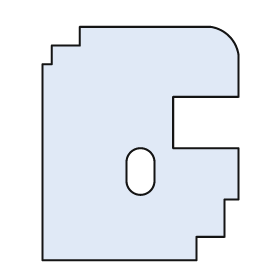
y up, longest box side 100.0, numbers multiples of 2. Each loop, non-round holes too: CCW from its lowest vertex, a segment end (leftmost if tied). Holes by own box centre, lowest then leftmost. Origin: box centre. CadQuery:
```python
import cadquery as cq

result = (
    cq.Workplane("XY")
    .moveTo(-42.0, -50.0)
    .lineTo(24.0, -50.0)
    .lineTo(24.0, -40.0)
    .lineTo(36.0, -40.0)
    .lineTo(36.0, -24.0)
    .lineTo(42.0, -24.0)
    .lineTo(42.0, -2.0)
    .lineTo(14.0, -2.0)
    .lineTo(14.0, 20.0)
    .lineTo(42.0, 20.0)
    .lineTo(42.0, 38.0)
    .threePointArc((38.0, 46.0), (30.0, 50.0))
    .lineTo(-26.0, 50.0)
    .lineTo(-26.0, 42.0)
    .lineTo(-38.0, 42.0)
    .lineTo(-38.0, 34.0)
    .lineTo(-42.0, 34.0)
    .close()
    .moveTo(-6.0, -16.0)
    .threePointArc((0.0, -22.0), (6.0, -16.0))
    .lineTo(6.0, -8.0)
    .threePointArc((0.0, -2.0), (-6.0, -8.0))
    .close()
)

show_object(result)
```